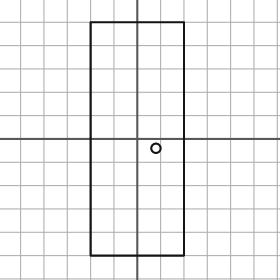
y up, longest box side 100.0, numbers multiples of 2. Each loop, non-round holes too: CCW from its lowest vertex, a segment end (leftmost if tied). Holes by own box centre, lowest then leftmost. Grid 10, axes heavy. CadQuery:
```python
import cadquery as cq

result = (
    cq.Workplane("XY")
    .moveTo(-20.0, -50.0)
    .lineTo(20.0, -50.0)
    .lineTo(20.0, 50.0)
    .lineTo(-20.0, 50.0)
    .close()
    .moveTo(8.0, -4.0)
    .circle(2.0)
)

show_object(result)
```